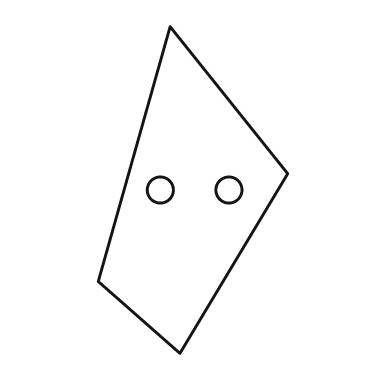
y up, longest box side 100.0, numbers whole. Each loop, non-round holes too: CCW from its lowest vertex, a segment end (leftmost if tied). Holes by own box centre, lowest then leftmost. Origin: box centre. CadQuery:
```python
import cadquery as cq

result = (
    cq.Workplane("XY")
    .moveTo(-4.0, -50.0)
    .lineTo(29.0, 5.0)
    .lineTo(-7.0, 50.0)
    .lineTo(-29.0, -28.0)
    .close()
    .moveTo(-10.0, 0.0)
    .circle(4.0)
    .moveTo(11.0, 0.0)
    .circle(4.0)
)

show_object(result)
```